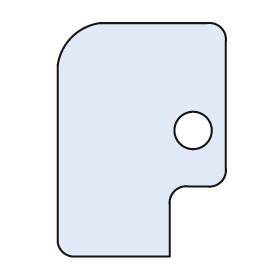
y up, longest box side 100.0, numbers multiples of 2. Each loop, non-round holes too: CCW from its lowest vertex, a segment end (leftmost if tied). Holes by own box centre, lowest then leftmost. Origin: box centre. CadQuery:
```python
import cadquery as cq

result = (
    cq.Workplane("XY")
    .moveTo(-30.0, -50.0)
    .lineTo(12.0, -50.0)
    .lineTo(12.0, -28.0)
    .threePointArc((14.0, -22.0), (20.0, -20.0))
    .lineTo(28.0, -20.0)
    .threePointArc((34.0, -18.0), (36.0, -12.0))
    .lineTo(36.0, 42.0)
    .threePointArc((34.0, 48.0), (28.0, 50.0))
    .lineTo(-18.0, 50.0)
    .threePointArc((-30.0, 44.0), (-36.0, 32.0))
    .lineTo(-36.0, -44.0)
    .threePointArc((-34.0, -48.0), (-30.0, -50.0))
    .close()
    .moveTo(22.0, 4.0)
    .circle(8.0)
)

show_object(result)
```